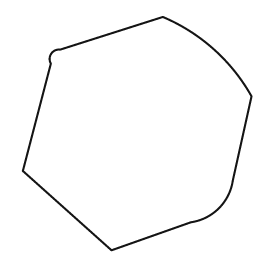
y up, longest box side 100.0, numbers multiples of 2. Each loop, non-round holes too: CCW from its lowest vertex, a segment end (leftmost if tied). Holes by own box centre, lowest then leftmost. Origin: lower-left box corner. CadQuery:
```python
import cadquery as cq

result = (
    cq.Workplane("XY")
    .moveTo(38.0, 0.0)
    .lineTo(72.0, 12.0)
    .threePointArc((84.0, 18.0), (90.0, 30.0))
    .lineTo(98.0, 66.0)
    .threePointArc((82.0, 86.0), (60.0, 100.0))
    .lineTo(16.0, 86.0)
    .threePointArc((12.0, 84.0), (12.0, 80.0))
    .lineTo(0.0, 34.0)
    .close()
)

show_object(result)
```